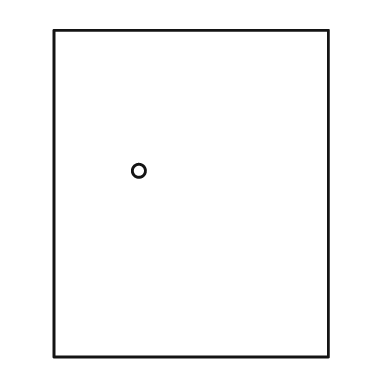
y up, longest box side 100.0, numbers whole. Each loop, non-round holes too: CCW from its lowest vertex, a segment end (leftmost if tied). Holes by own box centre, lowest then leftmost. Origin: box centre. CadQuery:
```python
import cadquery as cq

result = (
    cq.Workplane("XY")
    .moveTo(-42.0, -50.0)
    .lineTo(42.0, -50.0)
    .lineTo(42.0, 50.0)
    .lineTo(-42.0, 50.0)
    .close()
    .moveTo(-16.0, 7.0)
    .circle(2.0)
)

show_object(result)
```